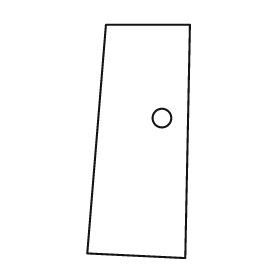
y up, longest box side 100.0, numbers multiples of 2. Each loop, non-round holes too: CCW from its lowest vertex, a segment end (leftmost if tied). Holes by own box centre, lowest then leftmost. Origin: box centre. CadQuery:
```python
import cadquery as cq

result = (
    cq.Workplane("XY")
    .moveTo(20.0, -50.0)
    .lineTo(22.0, 50.0)
    .lineTo(-14.0, 50.0)
    .lineTo(-22.0, -48.0)
    .close()
    .moveTo(10.0, 10.0)
    .circle(4.0)
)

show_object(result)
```